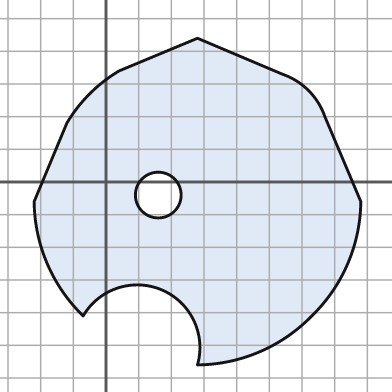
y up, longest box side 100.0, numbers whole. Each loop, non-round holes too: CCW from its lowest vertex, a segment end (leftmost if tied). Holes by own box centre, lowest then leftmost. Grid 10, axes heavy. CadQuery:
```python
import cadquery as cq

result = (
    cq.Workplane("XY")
    .moveTo(28.0, -56.0)
    .threePointArc((47.0, -52.0), (63.0, -41.0))
    .threePointArc((74.0, -25.0), (78.0, -6.0))
    .lineTo(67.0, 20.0)
    .threePointArc((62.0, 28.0), (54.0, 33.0))
    .lineTo(28.0, 44.0)
    .lineTo(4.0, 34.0)
    .threePointArc((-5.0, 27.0), (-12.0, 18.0))
    .lineTo(-22.0, -6.0)
    .threePointArc((-18.0, -25.0), (-7.0, -41.0))
    .threePointArc((17.0, -33.0), (28.0, -56.0))
    .close()
    .moveTo(16.0, -4.0)
    .circle(7.0)
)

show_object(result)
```